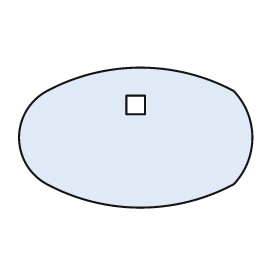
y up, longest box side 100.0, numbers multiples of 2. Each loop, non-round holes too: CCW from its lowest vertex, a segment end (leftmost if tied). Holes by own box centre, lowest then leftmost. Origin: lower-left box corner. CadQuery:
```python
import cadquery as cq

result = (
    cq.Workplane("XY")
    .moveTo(12.0, 10.0)
    .threePointArc((52.0, 0.0), (92.0, 10.0))
    .threePointArc((100.0, 30.0), (92.0, 50.0))
    .threePointArc((52.0, 60.0), (12.0, 50.0))
    .threePointArc((0.0, 30.0), (12.0, 10.0))
    .close()
    .moveTo(46.0, 40.0)
    .lineTo(54.0, 40.0)
    .lineTo(54.0, 48.0)
    .lineTo(46.0, 48.0)
    .close()
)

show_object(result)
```